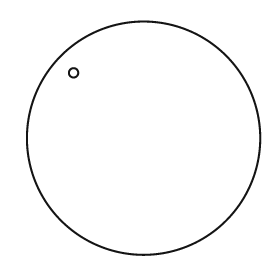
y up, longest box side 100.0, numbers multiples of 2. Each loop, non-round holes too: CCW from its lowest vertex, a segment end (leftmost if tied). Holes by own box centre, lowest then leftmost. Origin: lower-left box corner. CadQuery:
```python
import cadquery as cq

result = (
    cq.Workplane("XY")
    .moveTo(50.0, 50.0)
    .circle(50.0)
    .moveTo(20.0, 78.0)
    .circle(2.0)
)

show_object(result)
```